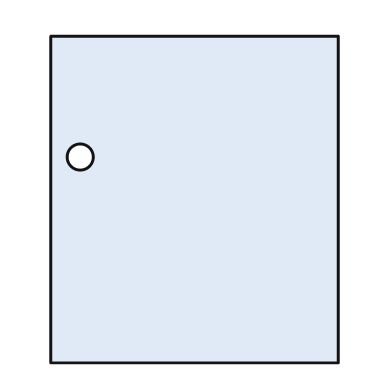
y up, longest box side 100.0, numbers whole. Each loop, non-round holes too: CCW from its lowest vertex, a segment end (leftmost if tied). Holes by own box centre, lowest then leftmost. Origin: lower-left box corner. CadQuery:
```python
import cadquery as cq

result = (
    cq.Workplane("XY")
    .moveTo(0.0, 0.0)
    .lineTo(88.0, 0.0)
    .lineTo(88.0, 100.0)
    .lineTo(0.0, 100.0)
    .close()
    .moveTo(9.0, 63.0)
    .circle(4.0)
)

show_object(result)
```